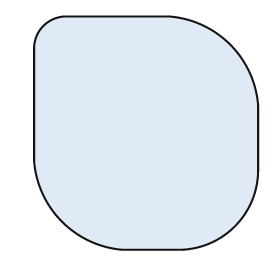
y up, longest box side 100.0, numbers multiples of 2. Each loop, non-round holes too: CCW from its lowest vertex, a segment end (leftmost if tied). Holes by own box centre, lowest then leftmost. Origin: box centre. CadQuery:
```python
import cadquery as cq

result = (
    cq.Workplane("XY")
    .moveTo(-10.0, -50.0)
    .lineTo(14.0, -50.0)
    .threePointArc((38.0, -40.0), (48.0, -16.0))
    .lineTo(48.0, 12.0)
    .threePointArc((36.0, 38.0), (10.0, 50.0))
    .lineTo(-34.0, 50.0)
    .threePointArc((-44.0, 46.0), (-48.0, 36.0))
    .lineTo(-48.0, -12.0)
    .threePointArc((-36.0, -38.0), (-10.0, -50.0))
    .close()
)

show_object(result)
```